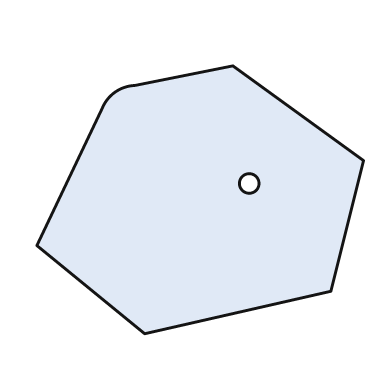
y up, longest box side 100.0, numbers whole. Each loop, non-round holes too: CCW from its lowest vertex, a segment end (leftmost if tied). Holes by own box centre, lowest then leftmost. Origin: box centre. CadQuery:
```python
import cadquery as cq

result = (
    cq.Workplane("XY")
    .moveTo(-17.0, -41.0)
    .lineTo(40.0, -28.0)
    .lineTo(50.0, 12.0)
    .lineTo(10.0, 41.0)
    .lineTo(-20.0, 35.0)
    .threePointArc((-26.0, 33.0), (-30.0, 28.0))
    .lineTo(-50.0, -14.0)
    .close()
    .moveTo(15.0, 5.0)
    .circle(3.0)
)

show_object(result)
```